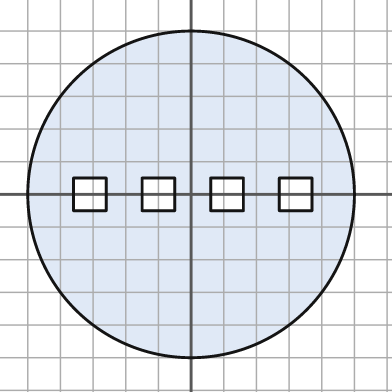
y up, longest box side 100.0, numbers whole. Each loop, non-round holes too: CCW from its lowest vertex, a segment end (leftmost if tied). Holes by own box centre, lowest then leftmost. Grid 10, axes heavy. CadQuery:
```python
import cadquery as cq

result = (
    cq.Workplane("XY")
    .moveTo(0.0, 0.0)
    .circle(50.0)
    .moveTo(-36.0, -5.0)
    .lineTo(-26.0, -5.0)
    .lineTo(-26.0, 5.0)
    .lineTo(-36.0, 5.0)
    .close()
    .moveTo(-15.0, -5.0)
    .lineTo(-5.0, -5.0)
    .lineTo(-5.0, 5.0)
    .lineTo(-15.0, 5.0)
    .close()
    .moveTo(6.0, -5.0)
    .lineTo(16.0, -5.0)
    .lineTo(16.0, 5.0)
    .lineTo(6.0, 5.0)
    .close()
    .moveTo(27.0, -5.0)
    .lineTo(37.0, -5.0)
    .lineTo(37.0, 5.0)
    .lineTo(27.0, 5.0)
    .close()
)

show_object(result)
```